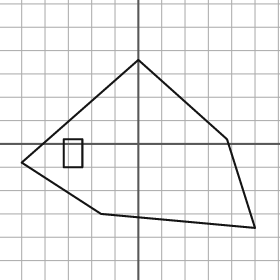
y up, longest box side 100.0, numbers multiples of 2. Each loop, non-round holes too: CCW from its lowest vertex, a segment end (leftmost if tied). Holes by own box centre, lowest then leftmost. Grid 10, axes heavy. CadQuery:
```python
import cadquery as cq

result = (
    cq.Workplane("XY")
    .moveTo(50.0, -36.0)
    .lineTo(38.0, 2.0)
    .lineTo(0.0, 36.0)
    .lineTo(-50.0, -8.0)
    .lineTo(-16.0, -30.0)
    .close()
    .moveTo(-32.0, -10.0)
    .lineTo(-24.0, -10.0)
    .lineTo(-24.0, 2.0)
    .lineTo(-32.0, 2.0)
    .close()
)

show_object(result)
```